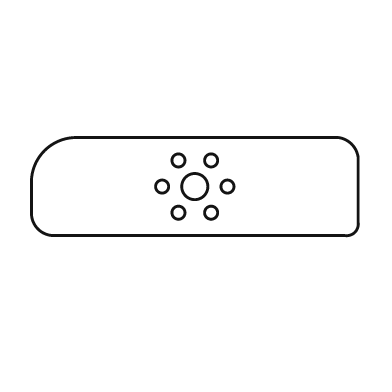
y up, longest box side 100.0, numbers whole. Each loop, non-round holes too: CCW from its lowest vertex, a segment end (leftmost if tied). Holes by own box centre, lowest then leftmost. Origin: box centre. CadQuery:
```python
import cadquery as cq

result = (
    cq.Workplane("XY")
    .moveTo(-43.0, -15.0)
    .lineTo(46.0, -15.0)
    .threePointArc((49.0, -14.0), (50.0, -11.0))
    .lineTo(50.0, 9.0)
    .threePointArc((48.0, 13.0), (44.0, 15.0))
    .lineTo(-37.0, 15.0)
    .threePointArc((-46.0, 11.0), (-50.0, 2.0))
    .lineTo(-50.0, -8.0)
    .threePointArc((-48.0, -13.0), (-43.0, -15.0))
    .close()
    .moveTo(-5.0, -8.0)
    .circle(2.0)
    .moveTo(5.0, -8.0)
    .circle(2.0)
    .moveTo(-10.0, 0.0)
    .circle(2.0)
    .moveTo(0.0, 0.0)
    .circle(4.0)
    .moveTo(10.0, 0.0)
    .circle(2.0)
    .moveTo(-5.0, 8.0)
    .circle(2.0)
    .moveTo(5.0, 8.0)
    .circle(2.0)
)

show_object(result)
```